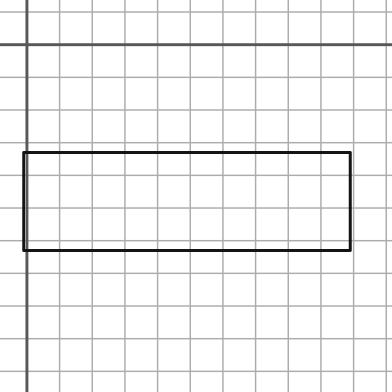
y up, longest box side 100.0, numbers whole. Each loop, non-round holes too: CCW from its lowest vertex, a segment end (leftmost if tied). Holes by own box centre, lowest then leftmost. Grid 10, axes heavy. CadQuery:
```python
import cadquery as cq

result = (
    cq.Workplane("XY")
    .moveTo(-1.0, -63.0)
    .lineTo(99.0, -63.0)
    .lineTo(99.0, -33.0)
    .lineTo(-1.0, -33.0)
    .close()
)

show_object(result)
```